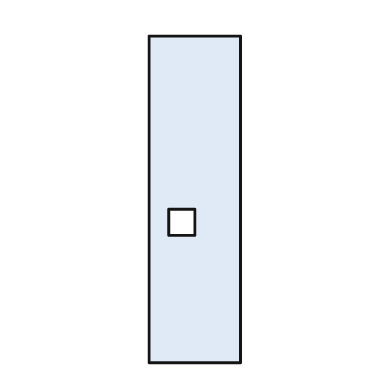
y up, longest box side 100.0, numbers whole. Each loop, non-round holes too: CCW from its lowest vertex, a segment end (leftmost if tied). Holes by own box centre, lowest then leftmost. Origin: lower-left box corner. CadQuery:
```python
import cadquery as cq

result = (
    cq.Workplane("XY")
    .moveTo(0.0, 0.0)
    .lineTo(28.0, 0.0)
    .lineTo(28.0, 100.0)
    .lineTo(0.0, 100.0)
    .close()
    .moveTo(6.0, 39.0)
    .lineTo(14.0, 39.0)
    .lineTo(14.0, 47.0)
    .lineTo(6.0, 47.0)
    .close()
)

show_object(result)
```